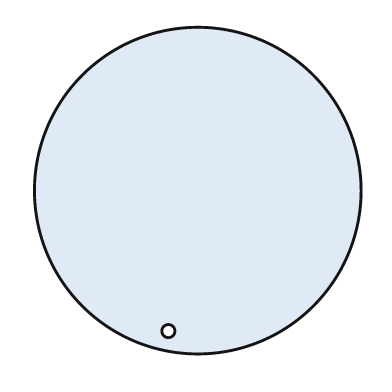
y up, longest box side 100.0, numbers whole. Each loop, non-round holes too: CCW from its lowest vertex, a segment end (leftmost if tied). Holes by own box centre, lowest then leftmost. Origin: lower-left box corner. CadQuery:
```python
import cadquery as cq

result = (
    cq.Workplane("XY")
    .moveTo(50.0, 50.0)
    .circle(50.0)
    .moveTo(41.0, 7.0)
    .circle(2.0)
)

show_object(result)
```